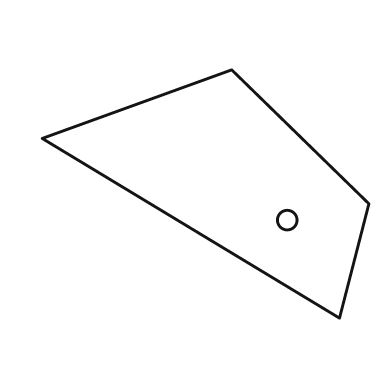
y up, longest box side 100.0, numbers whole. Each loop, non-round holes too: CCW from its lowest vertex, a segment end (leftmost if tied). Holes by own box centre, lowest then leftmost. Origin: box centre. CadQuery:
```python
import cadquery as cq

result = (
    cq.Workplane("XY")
    .moveTo(41.0, -38.0)
    .lineTo(50.0, -3.0)
    .lineTo(8.0, 38.0)
    .lineTo(-50.0, 17.0)
    .close()
    .moveTo(25.0, -8.0)
    .circle(3.0)
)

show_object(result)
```